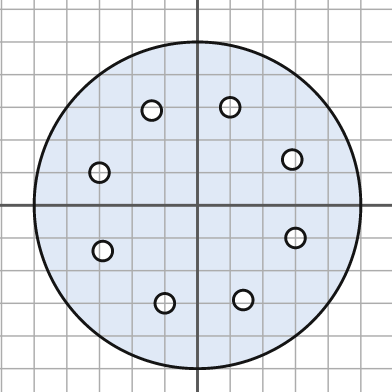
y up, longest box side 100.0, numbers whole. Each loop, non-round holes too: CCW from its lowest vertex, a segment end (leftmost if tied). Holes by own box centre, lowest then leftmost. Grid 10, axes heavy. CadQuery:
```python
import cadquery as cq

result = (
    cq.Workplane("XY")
    .moveTo(0.0, 0.0)
    .circle(50.0)
    .moveTo(-10.0, -30.0)
    .circle(3.0)
    .moveTo(14.0, -29.0)
    .circle(3.0)
    .moveTo(-29.0, -14.0)
    .circle(3.0)
    .moveTo(30.0, -10.0)
    .circle(3.0)
    .moveTo(-30.0, 10.0)
    .circle(3.0)
    .moveTo(29.0, 14.0)
    .circle(3.0)
    .moveTo(-14.0, 29.0)
    .circle(3.0)
    .moveTo(10.0, 30.0)
    .circle(3.0)
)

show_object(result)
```